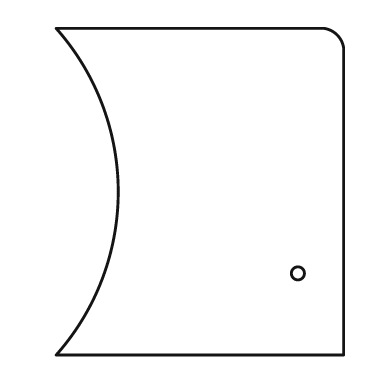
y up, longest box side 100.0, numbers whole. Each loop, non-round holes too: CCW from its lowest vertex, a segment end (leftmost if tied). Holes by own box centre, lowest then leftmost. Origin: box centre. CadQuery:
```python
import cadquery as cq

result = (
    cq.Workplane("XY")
    .moveTo(-44.0, -50.0)
    .lineTo(44.0, -50.0)
    .lineTo(44.0, 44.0)
    .threePointArc((42.0, 48.0), (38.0, 50.0))
    .lineTo(-44.0, 50.0)
    .threePointArc((-25.0, 0.0), (-44.0, -50.0))
    .close()
    .moveTo(30.0, -25.0)
    .circle(2.0)
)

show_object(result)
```